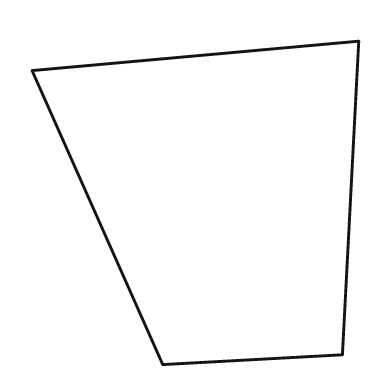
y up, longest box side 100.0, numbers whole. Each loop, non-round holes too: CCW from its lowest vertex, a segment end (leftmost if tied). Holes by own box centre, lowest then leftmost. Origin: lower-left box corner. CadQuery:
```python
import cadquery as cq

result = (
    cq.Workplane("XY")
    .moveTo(40.0, 0.0)
    .lineTo(95.0, 3.0)
    .lineTo(100.0, 99.0)
    .lineTo(0.0, 90.0)
    .close()
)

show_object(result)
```